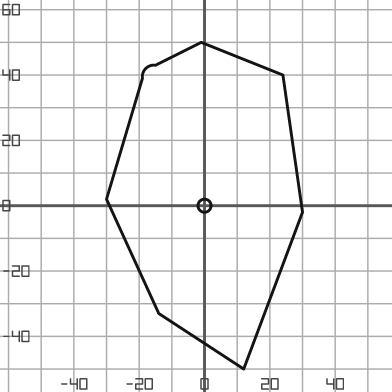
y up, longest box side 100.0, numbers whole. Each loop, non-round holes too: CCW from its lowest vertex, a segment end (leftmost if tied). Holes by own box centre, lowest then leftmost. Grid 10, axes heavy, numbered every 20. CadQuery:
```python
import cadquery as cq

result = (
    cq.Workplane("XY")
    .moveTo(12.0, -50.0)
    .lineTo(30.0, -2.0)
    .lineTo(24.0, 40.0)
    .lineTo(-1.0, 50.0)
    .lineTo(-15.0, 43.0)
    .threePointArc((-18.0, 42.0), (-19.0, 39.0))
    .lineTo(-30.0, 2.0)
    .lineTo(-14.0, -33.0)
    .close()
    .moveTo(0.0, 0.0)
    .circle(2.0)
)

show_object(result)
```